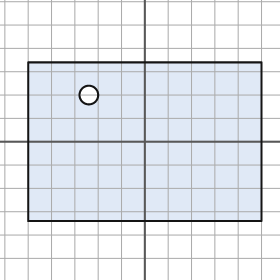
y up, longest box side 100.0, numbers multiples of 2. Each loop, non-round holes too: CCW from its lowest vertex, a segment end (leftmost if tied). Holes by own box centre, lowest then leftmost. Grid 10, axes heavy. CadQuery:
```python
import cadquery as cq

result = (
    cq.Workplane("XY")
    .moveTo(-50.0, -34.0)
    .lineTo(50.0, -34.0)
    .lineTo(50.0, 34.0)
    .lineTo(-50.0, 34.0)
    .close()
    .moveTo(-24.0, 20.0)
    .circle(4.0)
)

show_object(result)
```